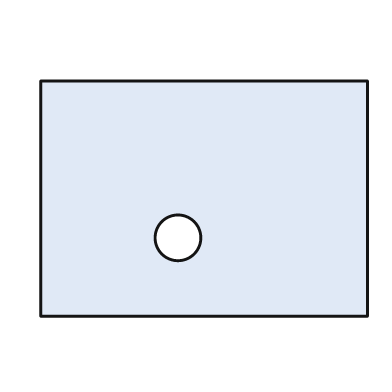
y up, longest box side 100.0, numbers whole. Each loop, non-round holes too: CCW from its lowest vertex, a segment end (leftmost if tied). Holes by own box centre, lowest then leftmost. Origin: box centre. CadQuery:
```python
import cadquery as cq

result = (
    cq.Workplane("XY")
    .moveTo(-50.0, -36.0)
    .lineTo(50.0, -36.0)
    .lineTo(50.0, 36.0)
    .lineTo(-50.0, 36.0)
    .close()
    .moveTo(-8.0, -12.0)
    .circle(7.0)
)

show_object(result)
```